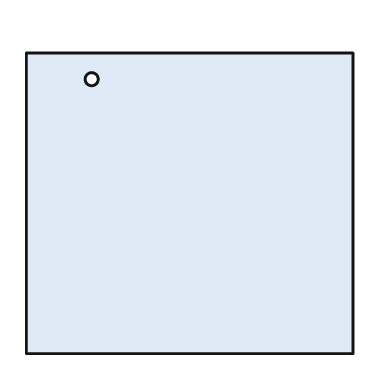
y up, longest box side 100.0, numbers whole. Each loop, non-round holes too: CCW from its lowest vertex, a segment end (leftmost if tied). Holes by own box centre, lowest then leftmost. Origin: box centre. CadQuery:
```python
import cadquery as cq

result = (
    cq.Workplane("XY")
    .moveTo(-50.0, -46.0)
    .lineTo(50.0, -46.0)
    .lineTo(50.0, 46.0)
    .lineTo(-50.0, 46.0)
    .close()
    .moveTo(-30.0, 38.0)
    .circle(2.0)
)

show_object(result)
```